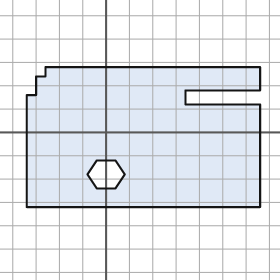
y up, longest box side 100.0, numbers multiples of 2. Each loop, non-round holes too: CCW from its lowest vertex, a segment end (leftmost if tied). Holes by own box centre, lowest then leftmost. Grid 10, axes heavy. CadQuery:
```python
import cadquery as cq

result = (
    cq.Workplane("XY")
    .moveTo(-34.0, -32.0)
    .lineTo(66.0, -32.0)
    .lineTo(66.0, 12.0)
    .lineTo(34.0, 12.0)
    .lineTo(34.0, 18.0)
    .lineTo(66.0, 18.0)
    .lineTo(66.0, 28.0)
    .lineTo(-26.0, 28.0)
    .lineTo(-26.0, 24.0)
    .lineTo(-30.0, 24.0)
    .lineTo(-30.0, 16.0)
    .lineTo(-34.0, 16.0)
    .close()
    .moveTo(-4.0, -24.0)
    .lineTo(4.0, -24.0)
    .lineTo(8.0, -18.0)
    .lineTo(4.0, -12.0)
    .lineTo(-4.0, -12.0)
    .lineTo(-8.0, -18.0)
    .close()
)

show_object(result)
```